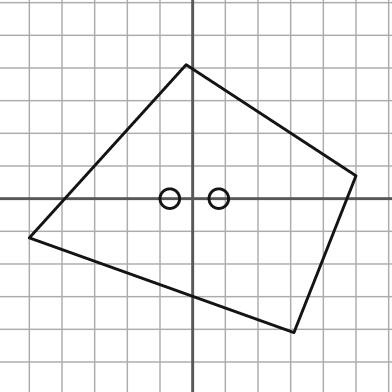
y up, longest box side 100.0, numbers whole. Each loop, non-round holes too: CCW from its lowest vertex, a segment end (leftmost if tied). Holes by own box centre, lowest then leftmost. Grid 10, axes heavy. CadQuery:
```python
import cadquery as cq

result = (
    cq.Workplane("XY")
    .moveTo(31.0, -41.0)
    .lineTo(50.0, 7.0)
    .lineTo(-2.0, 41.0)
    .lineTo(-50.0, -12.0)
    .close()
    .moveTo(-7.0, 0.0)
    .circle(3.0)
    .moveTo(8.0, 0.0)
    .circle(3.0)
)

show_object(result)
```